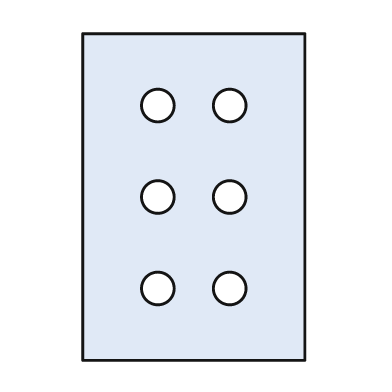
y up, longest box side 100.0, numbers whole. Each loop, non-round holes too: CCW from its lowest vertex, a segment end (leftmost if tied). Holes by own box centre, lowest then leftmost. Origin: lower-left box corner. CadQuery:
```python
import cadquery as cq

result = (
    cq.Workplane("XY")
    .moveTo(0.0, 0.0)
    .lineTo(68.0, 0.0)
    .lineTo(68.0, 100.0)
    .lineTo(0.0, 100.0)
    .close()
    .moveTo(23.0, 22.0)
    .circle(5.0)
    .moveTo(45.0, 22.0)
    .circle(5.0)
    .moveTo(23.0, 50.0)
    .circle(5.0)
    .moveTo(45.0, 50.0)
    .circle(5.0)
    .moveTo(23.0, 78.0)
    .circle(5.0)
    .moveTo(45.0, 78.0)
    .circle(5.0)
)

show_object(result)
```